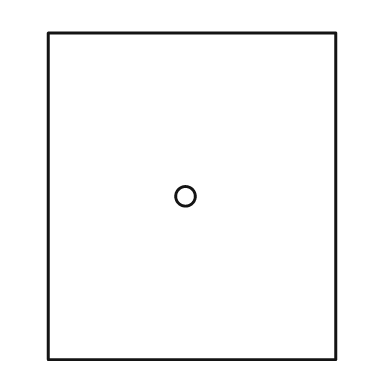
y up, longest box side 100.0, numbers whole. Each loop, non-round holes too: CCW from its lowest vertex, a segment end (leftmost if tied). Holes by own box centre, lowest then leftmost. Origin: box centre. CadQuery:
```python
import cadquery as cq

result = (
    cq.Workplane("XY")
    .moveTo(-44.0, -50.0)
    .lineTo(44.0, -50.0)
    .lineTo(44.0, 50.0)
    .lineTo(-44.0, 50.0)
    .close()
    .moveTo(-2.0, 0.0)
    .circle(3.0)
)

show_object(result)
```